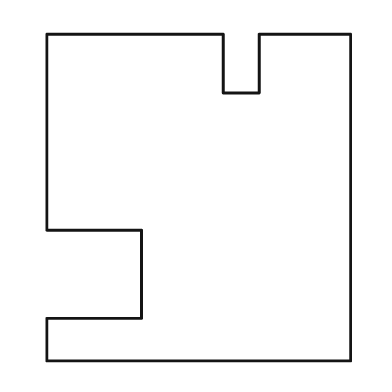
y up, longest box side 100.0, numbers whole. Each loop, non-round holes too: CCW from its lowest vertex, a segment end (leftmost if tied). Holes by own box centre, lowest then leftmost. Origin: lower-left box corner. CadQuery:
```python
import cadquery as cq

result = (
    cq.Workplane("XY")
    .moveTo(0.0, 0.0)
    .lineTo(93.0, 0.0)
    .lineTo(93.0, 100.0)
    .lineTo(65.0, 100.0)
    .lineTo(65.0, 82.0)
    .lineTo(54.0, 82.0)
    .lineTo(54.0, 100.0)
    .lineTo(0.0, 100.0)
    .lineTo(0.0, 40.0)
    .lineTo(29.0, 40.0)
    .lineTo(29.0, 13.0)
    .lineTo(0.0, 13.0)
    .close()
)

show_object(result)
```